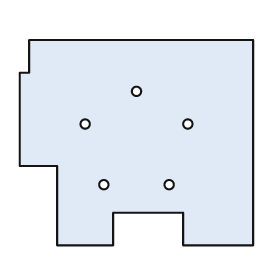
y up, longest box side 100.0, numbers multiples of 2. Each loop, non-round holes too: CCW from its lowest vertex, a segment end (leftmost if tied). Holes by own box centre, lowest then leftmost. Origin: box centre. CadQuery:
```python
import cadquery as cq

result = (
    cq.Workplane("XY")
    .moveTo(-34.0, -44.0)
    .lineTo(-10.0, -44.0)
    .lineTo(-10.0, -30.0)
    .lineTo(20.0, -30.0)
    .lineTo(20.0, -44.0)
    .lineTo(50.0, -44.0)
    .lineTo(50.0, 44.0)
    .lineTo(-46.0, 44.0)
    .lineTo(-46.0, 30.0)
    .lineTo(-50.0, 30.0)
    .lineTo(-50.0, -10.0)
    .lineTo(-34.0, -10.0)
    .close()
    .moveTo(-14.0, -18.0)
    .circle(2.0)
    .moveTo(14.0, -18.0)
    .circle(2.0)
    .moveTo(-22.0, 8.0)
    .circle(2.0)
    .moveTo(22.0, 8.0)
    .circle(2.0)
    .moveTo(0.0, 22.0)
    .circle(2.0)
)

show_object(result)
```